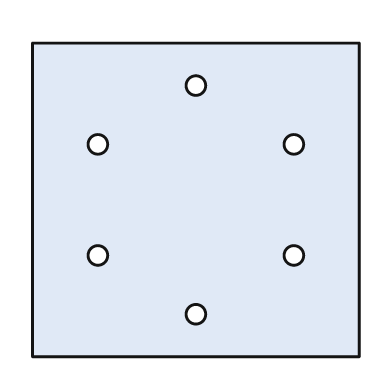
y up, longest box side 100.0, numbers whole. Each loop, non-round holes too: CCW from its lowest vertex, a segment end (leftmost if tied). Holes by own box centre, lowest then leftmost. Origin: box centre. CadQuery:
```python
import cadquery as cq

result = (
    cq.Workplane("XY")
    .moveTo(-50.0, -48.0)
    .lineTo(50.0, -48.0)
    .lineTo(50.0, 48.0)
    .lineTo(-50.0, 48.0)
    .close()
    .moveTo(0.0, -35.0)
    .circle(3.0)
    .moveTo(-30.0, -17.0)
    .circle(3.0)
    .moveTo(30.0, -17.0)
    .circle(3.0)
    .moveTo(-30.0, 17.0)
    .circle(3.0)
    .moveTo(30.0, 17.0)
    .circle(3.0)
    .moveTo(0.0, 35.0)
    .circle(3.0)
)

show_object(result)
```